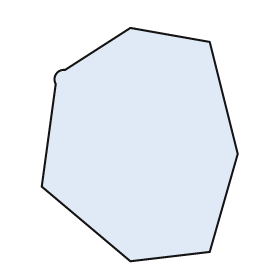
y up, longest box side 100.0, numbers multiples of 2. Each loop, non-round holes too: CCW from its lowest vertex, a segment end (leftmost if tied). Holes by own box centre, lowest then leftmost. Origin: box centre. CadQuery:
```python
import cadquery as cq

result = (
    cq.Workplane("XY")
    .moveTo(-4.0, -50.0)
    .lineTo(30.0, -46.0)
    .lineTo(42.0, -4.0)
    .lineTo(30.0, 44.0)
    .lineTo(-4.0, 50.0)
    .lineTo(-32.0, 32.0)
    .threePointArc((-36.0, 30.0), (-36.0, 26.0))
    .lineTo(-42.0, -18.0)
    .close()
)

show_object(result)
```